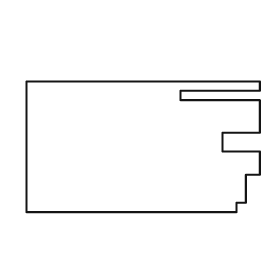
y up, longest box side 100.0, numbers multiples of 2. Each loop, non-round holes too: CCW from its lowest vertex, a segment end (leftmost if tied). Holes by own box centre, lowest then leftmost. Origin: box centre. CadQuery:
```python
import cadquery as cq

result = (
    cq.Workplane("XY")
    .moveTo(-50.0, -28.0)
    .lineTo(40.0, -28.0)
    .lineTo(40.0, -24.0)
    .lineTo(44.0, -24.0)
    .lineTo(44.0, -12.0)
    .lineTo(50.0, -12.0)
    .lineTo(50.0, -2.0)
    .lineTo(34.0, -2.0)
    .lineTo(34.0, 6.0)
    .lineTo(50.0, 6.0)
    .lineTo(50.0, 20.0)
    .lineTo(16.0, 20.0)
    .lineTo(16.0, 24.0)
    .lineTo(50.0, 24.0)
    .lineTo(50.0, 28.0)
    .lineTo(-50.0, 28.0)
    .close()
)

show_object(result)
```